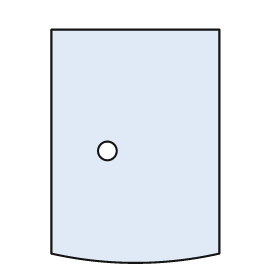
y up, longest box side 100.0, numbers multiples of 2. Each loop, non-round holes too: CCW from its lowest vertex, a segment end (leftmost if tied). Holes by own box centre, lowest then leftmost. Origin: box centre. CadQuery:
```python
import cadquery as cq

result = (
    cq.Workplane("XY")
    .moveTo(-36.0, -46.0)
    .threePointArc((0.0, -50.0), (36.0, -46.0))
    .lineTo(36.0, 50.0)
    .lineTo(-36.0, 50.0)
    .close()
    .moveTo(-12.0, -2.0)
    .circle(4.0)
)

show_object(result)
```